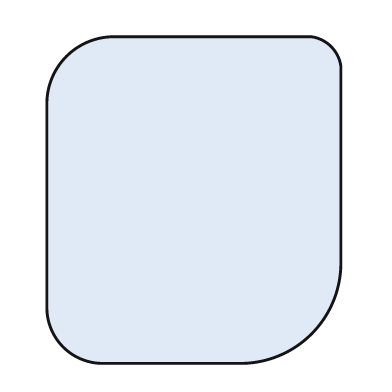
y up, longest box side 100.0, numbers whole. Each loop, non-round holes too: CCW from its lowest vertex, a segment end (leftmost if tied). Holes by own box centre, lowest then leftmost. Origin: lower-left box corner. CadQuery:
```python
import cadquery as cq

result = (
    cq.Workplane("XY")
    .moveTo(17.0, 0.0)
    .lineTo(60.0, 0.0)
    .threePointArc((81.0, 9.0), (90.0, 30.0))
    .lineTo(90.0, 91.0)
    .threePointArc((87.0, 97.0), (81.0, 100.0))
    .lineTo(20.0, 100.0)
    .threePointArc((6.0, 94.0), (0.0, 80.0))
    .lineTo(0.0, 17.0)
    .threePointArc((5.0, 5.0), (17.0, 0.0))
    .close()
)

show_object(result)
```